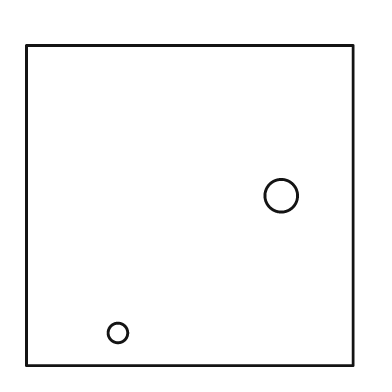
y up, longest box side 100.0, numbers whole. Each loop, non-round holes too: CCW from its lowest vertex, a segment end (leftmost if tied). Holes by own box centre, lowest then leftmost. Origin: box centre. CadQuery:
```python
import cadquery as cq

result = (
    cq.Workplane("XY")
    .moveTo(-50.0, -49.0)
    .lineTo(50.0, -49.0)
    .lineTo(50.0, 49.0)
    .lineTo(-50.0, 49.0)
    .close()
    .moveTo(-22.0, -39.0)
    .circle(3.0)
    .moveTo(28.0, 3.0)
    .circle(5.0)
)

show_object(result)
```